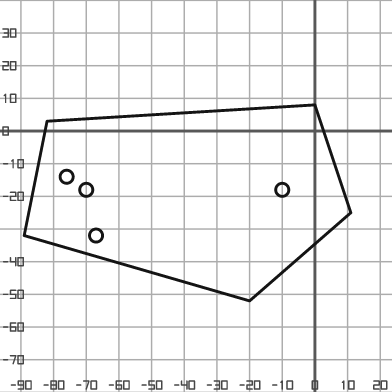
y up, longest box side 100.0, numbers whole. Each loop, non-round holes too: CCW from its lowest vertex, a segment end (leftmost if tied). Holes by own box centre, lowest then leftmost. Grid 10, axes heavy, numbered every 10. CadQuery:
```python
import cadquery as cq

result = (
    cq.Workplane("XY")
    .moveTo(-20.0, -52.0)
    .lineTo(11.0, -25.0)
    .lineTo(0.0, 8.0)
    .lineTo(-82.0, 3.0)
    .lineTo(-89.0, -32.0)
    .close()
    .moveTo(-67.0, -32.0)
    .circle(2.0)
    .moveTo(-70.0, -18.0)
    .circle(2.0)
    .moveTo(-10.0, -18.0)
    .circle(2.0)
    .moveTo(-76.0, -14.0)
    .circle(2.0)
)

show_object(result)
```